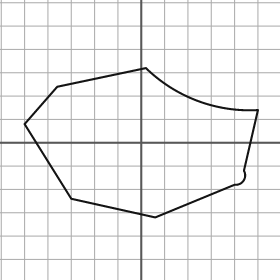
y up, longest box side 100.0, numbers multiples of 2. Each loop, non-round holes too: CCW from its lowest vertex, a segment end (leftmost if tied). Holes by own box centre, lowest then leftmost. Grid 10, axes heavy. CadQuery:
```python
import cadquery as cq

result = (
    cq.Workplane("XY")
    .moveTo(6.0, -32.0)
    .lineTo(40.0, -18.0)
    .threePointArc((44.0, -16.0), (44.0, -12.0))
    .lineTo(50.0, 14.0)
    .threePointArc((24.0, 18.0), (2.0, 32.0))
    .lineTo(-36.0, 24.0)
    .lineTo(-50.0, 8.0)
    .lineTo(-30.0, -24.0)
    .close()
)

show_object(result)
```